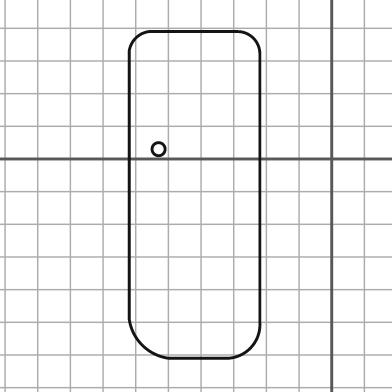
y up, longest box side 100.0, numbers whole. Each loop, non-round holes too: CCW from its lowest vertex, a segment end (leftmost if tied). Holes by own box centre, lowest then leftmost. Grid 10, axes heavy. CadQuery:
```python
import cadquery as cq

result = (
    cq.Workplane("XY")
    .moveTo(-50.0, -61.0)
    .lineTo(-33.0, -61.0)
    .threePointArc((-25.0, -58.0), (-22.0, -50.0))
    .lineTo(-22.0, 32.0)
    .threePointArc((-24.0, 37.0), (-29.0, 39.0))
    .lineTo(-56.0, 39.0)
    .threePointArc((-60.0, 37.0), (-62.0, 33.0))
    .lineTo(-62.0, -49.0)
    .threePointArc((-58.0, -57.0), (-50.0, -61.0))
    .close()
    .moveTo(-53.0, 3.0)
    .circle(2.0)
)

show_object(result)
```